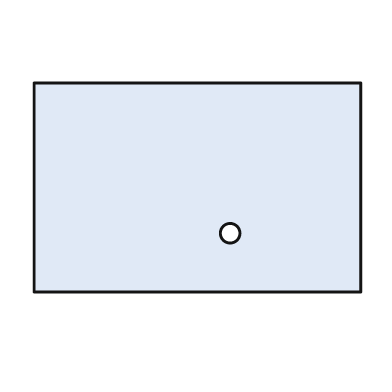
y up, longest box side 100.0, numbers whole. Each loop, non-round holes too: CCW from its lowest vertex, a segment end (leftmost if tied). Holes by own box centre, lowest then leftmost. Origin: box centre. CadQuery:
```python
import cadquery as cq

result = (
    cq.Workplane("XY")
    .moveTo(-50.0, -32.0)
    .lineTo(50.0, -32.0)
    .lineTo(50.0, 32.0)
    .lineTo(-50.0, 32.0)
    .close()
    .moveTo(10.0, -14.0)
    .circle(3.0)
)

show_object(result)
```